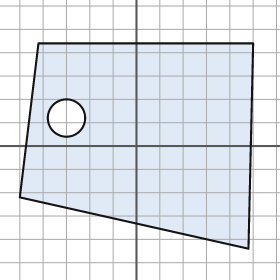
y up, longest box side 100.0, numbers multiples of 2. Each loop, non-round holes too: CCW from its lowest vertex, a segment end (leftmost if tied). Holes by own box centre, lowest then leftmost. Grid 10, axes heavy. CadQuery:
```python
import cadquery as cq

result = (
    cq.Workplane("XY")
    .moveTo(48.0, -44.0)
    .lineTo(50.0, 44.0)
    .lineTo(-42.0, 44.0)
    .lineTo(-50.0, -22.0)
    .close()
    .moveTo(-30.0, 12.0)
    .circle(8.0)
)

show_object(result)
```